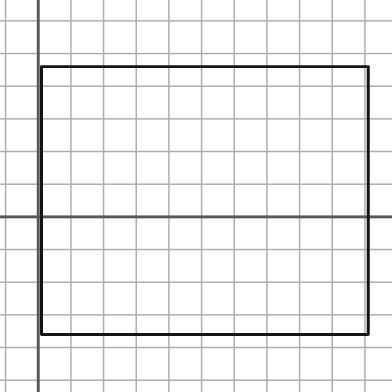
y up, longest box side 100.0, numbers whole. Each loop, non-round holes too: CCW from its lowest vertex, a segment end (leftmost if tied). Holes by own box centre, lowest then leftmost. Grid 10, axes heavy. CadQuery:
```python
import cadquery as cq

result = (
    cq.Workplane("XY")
    .moveTo(1.0, -36.0)
    .lineTo(101.0, -36.0)
    .lineTo(101.0, 46.0)
    .lineTo(1.0, 46.0)
    .close()
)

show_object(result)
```